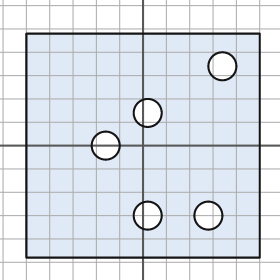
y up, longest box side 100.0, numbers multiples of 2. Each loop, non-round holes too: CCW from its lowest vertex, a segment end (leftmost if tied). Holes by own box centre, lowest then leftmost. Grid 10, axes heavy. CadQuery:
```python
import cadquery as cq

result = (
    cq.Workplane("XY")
    .moveTo(-50.0, -48.0)
    .lineTo(50.0, -48.0)
    .lineTo(50.0, 48.0)
    .lineTo(-50.0, 48.0)
    .close()
    .moveTo(2.0, -30.0)
    .circle(6.0)
    .moveTo(28.0, -30.0)
    .circle(6.0)
    .moveTo(-16.0, 0.0)
    .circle(6.0)
    .moveTo(2.0, 14.0)
    .circle(6.0)
    .moveTo(34.0, 34.0)
    .circle(6.0)
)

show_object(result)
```